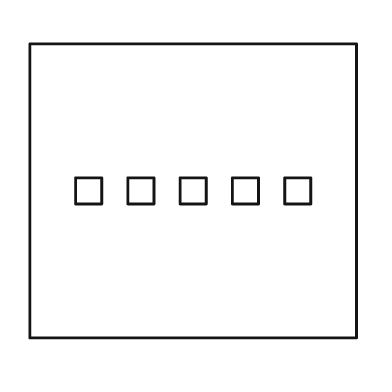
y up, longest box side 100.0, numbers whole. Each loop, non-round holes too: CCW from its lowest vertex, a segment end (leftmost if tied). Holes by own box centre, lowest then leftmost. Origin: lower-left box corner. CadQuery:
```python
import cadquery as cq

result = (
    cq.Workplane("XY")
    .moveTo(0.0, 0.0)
    .lineTo(100.0, 0.0)
    .lineTo(100.0, 90.0)
    .lineTo(0.0, 90.0)
    .close()
    .moveTo(14.0, 41.0)
    .lineTo(22.0, 41.0)
    .lineTo(22.0, 49.0)
    .lineTo(14.0, 49.0)
    .close()
    .moveTo(30.0, 41.0)
    .lineTo(38.0, 41.0)
    .lineTo(38.0, 49.0)
    .lineTo(30.0, 49.0)
    .close()
    .moveTo(46.0, 41.0)
    .lineTo(54.0, 41.0)
    .lineTo(54.0, 49.0)
    .lineTo(46.0, 49.0)
    .close()
    .moveTo(62.0, 41.0)
    .lineTo(70.0, 41.0)
    .lineTo(70.0, 49.0)
    .lineTo(62.0, 49.0)
    .close()
    .moveTo(78.0, 41.0)
    .lineTo(86.0, 41.0)
    .lineTo(86.0, 49.0)
    .lineTo(78.0, 49.0)
    .close()
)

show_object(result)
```